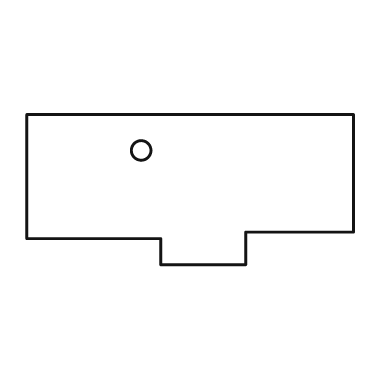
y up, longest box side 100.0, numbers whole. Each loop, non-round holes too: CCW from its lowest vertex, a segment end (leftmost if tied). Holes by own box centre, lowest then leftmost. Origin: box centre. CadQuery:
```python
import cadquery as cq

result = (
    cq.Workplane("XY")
    .moveTo(-9.0, -23.0)
    .lineTo(17.0, -23.0)
    .lineTo(17.0, -13.0)
    .lineTo(50.0, -13.0)
    .lineTo(50.0, 23.0)
    .lineTo(-50.0, 23.0)
    .lineTo(-50.0, -15.0)
    .lineTo(-9.0, -15.0)
    .close()
    .moveTo(-15.0, 12.0)
    .circle(3.0)
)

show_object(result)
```